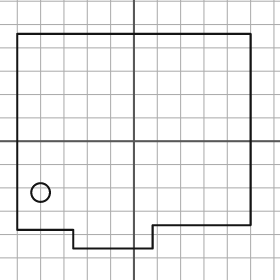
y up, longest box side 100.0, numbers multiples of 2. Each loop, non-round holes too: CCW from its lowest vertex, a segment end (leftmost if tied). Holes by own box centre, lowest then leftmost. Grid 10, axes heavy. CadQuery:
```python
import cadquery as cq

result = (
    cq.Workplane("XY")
    .moveTo(-26.0, -46.0)
    .lineTo(8.0, -46.0)
    .lineTo(8.0, -36.0)
    .lineTo(50.0, -36.0)
    .lineTo(50.0, 46.0)
    .lineTo(-50.0, 46.0)
    .lineTo(-50.0, -38.0)
    .lineTo(-26.0, -38.0)
    .close()
    .moveTo(-40.0, -22.0)
    .circle(4.0)
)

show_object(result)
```